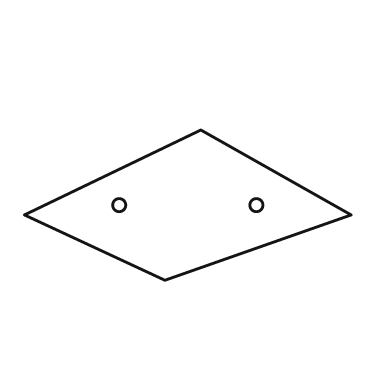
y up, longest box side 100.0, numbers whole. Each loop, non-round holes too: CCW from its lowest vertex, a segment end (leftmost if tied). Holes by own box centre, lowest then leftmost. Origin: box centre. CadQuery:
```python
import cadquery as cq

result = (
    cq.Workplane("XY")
    .moveTo(-7.0, -23.0)
    .lineTo(50.0, -3.0)
    .lineTo(4.0, 23.0)
    .lineTo(-50.0, -3.0)
    .close()
    .moveTo(-21.0, 0.0)
    .circle(2.0)
    .moveTo(21.0, 0.0)
    .circle(2.0)
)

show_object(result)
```